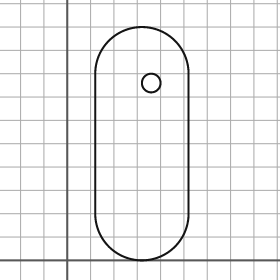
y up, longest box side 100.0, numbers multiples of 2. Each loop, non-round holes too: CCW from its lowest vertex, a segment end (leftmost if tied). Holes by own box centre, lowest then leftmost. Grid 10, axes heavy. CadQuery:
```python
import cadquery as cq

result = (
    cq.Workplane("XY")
    .moveTo(12.0, 20.0)
    .threePointArc((32.0, 0.0), (52.0, 20.0))
    .lineTo(52.0, 80.0)
    .threePointArc((32.0, 100.0), (12.0, 80.0))
    .close()
    .moveTo(36.0, 76.0)
    .circle(4.0)
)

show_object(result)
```